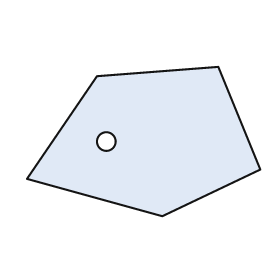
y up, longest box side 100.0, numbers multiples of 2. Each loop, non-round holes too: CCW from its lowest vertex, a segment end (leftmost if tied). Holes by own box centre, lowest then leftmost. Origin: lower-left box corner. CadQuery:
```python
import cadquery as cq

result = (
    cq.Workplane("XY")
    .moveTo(58.0, 0.0)
    .lineTo(100.0, 20.0)
    .lineTo(82.0, 64.0)
    .lineTo(30.0, 60.0)
    .lineTo(0.0, 16.0)
    .close()
    .moveTo(34.0, 32.0)
    .circle(4.0)
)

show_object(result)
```